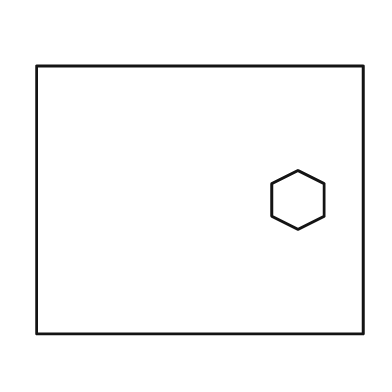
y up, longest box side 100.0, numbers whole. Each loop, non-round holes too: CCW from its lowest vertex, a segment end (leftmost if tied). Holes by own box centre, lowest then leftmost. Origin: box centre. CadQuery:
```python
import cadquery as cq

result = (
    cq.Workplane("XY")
    .moveTo(-50.0, -41.0)
    .lineTo(50.0, -41.0)
    .lineTo(50.0, 41.0)
    .lineTo(-50.0, 41.0)
    .close()
    .moveTo(30.0, -9.0)
    .lineTo(38.0, -5.0)
    .lineTo(38.0, 5.0)
    .lineTo(30.0, 9.0)
    .lineTo(22.0, 5.0)
    .lineTo(22.0, -5.0)
    .close()
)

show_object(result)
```